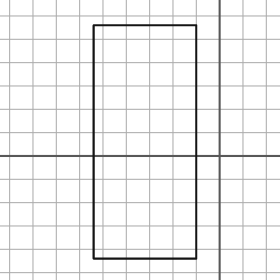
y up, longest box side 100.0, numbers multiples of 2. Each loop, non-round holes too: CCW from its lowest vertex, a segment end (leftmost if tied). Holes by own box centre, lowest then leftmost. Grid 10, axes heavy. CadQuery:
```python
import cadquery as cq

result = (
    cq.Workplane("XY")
    .moveTo(-54.0, -44.0)
    .lineTo(-10.0, -44.0)
    .lineTo(-10.0, 56.0)
    .lineTo(-54.0, 56.0)
    .close()
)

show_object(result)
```